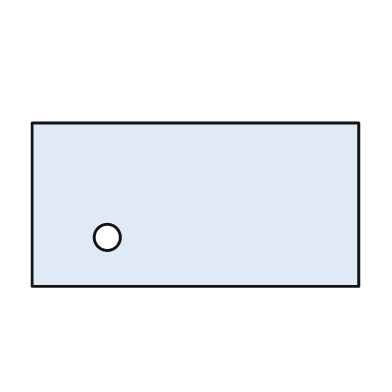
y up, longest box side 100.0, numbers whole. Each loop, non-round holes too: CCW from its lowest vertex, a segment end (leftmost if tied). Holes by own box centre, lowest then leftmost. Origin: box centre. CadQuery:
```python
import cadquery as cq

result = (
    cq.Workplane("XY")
    .moveTo(-50.0, -25.0)
    .lineTo(50.0, -25.0)
    .lineTo(50.0, 25.0)
    .lineTo(-50.0, 25.0)
    .close()
    .moveTo(-27.0, -10.0)
    .circle(4.0)
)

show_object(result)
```